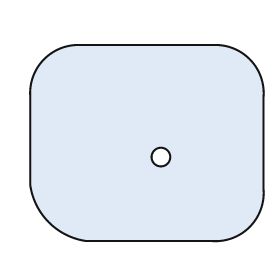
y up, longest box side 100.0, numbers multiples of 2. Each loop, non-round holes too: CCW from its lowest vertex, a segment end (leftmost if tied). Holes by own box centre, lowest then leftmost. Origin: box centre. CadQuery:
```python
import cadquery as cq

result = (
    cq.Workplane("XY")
    .moveTo(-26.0, -42.0)
    .lineTo(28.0, -42.0)
    .threePointArc((44.0, -36.0), (50.0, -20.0))
    .lineTo(50.0, 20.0)
    .threePointArc((44.0, 36.0), (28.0, 42.0))
    .lineTo(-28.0, 42.0)
    .threePointArc((-44.0, 36.0), (-50.0, 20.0))
    .lineTo(-50.0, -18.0)
    .threePointArc((-42.0, -34.0), (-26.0, -42.0))
    .close()
    .moveTo(6.0, -6.0)
    .circle(4.0)
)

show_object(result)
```